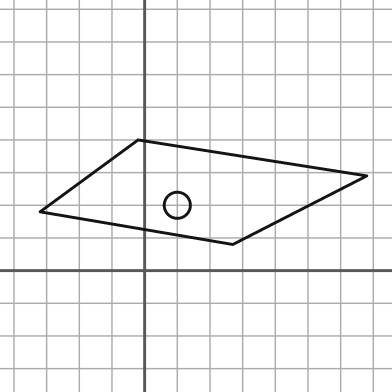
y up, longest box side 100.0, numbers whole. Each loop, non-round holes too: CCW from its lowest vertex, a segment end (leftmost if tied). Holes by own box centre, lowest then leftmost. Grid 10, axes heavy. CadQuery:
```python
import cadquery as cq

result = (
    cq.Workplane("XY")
    .moveTo(27.0, 8.0)
    .lineTo(68.0, 29.0)
    .lineTo(-2.0, 40.0)
    .lineTo(-32.0, 18.0)
    .close()
    .moveTo(10.0, 20.0)
    .circle(4.0)
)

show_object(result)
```